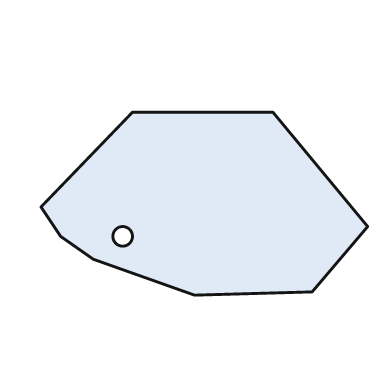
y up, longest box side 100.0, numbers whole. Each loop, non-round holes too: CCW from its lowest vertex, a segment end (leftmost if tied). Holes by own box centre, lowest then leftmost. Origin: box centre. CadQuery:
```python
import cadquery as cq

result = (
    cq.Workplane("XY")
    .moveTo(-3.0, -28.0)
    .lineTo(33.0, -27.0)
    .lineTo(50.0, -7.0)
    .lineTo(21.0, 28.0)
    .lineTo(-22.0, 28.0)
    .lineTo(-50.0, -1.0)
    .lineTo(-44.0, -10.0)
    .lineTo(-34.0, -17.0)
    .close()
    .moveTo(-25.0, -10.0)
    .circle(3.0)
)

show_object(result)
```